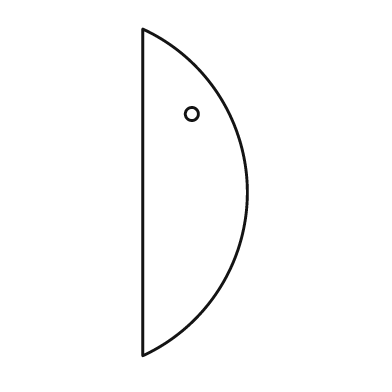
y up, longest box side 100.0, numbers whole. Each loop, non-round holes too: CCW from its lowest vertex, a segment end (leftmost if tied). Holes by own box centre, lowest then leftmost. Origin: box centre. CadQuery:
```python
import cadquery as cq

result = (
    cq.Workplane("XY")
    .moveTo(-16.0, -50.0)
    .threePointArc((16.0, 0.0), (-16.0, 50.0))
    .close()
    .moveTo(-1.0, 24.0)
    .circle(2.0)
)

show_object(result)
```